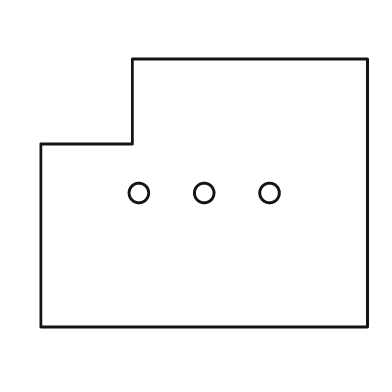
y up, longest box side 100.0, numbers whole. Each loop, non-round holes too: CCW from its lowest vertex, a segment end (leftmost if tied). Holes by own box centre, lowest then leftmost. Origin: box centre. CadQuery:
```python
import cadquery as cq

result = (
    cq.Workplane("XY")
    .moveTo(-50.0, -41.0)
    .lineTo(50.0, -41.0)
    .lineTo(50.0, 41.0)
    .lineTo(-22.0, 41.0)
    .lineTo(-22.0, 15.0)
    .lineTo(-50.0, 15.0)
    .close()
    .moveTo(-20.0, 0.0)
    .circle(3.0)
    .moveTo(0.0, 0.0)
    .circle(3.0)
    .moveTo(20.0, 0.0)
    .circle(3.0)
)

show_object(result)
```